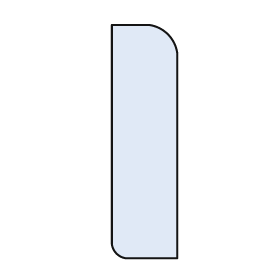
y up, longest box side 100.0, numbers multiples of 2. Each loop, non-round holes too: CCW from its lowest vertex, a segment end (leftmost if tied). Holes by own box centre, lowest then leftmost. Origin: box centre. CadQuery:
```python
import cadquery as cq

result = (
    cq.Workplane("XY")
    .moveTo(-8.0, -50.0)
    .lineTo(14.0, -50.0)
    .lineTo(14.0, 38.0)
    .threePointArc((10.0, 46.0), (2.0, 50.0))
    .lineTo(-14.0, 50.0)
    .lineTo(-14.0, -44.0)
    .threePointArc((-12.0, -48.0), (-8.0, -50.0))
    .close()
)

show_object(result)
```